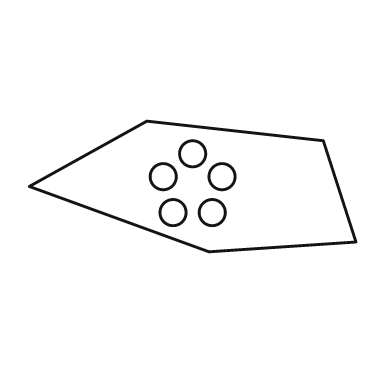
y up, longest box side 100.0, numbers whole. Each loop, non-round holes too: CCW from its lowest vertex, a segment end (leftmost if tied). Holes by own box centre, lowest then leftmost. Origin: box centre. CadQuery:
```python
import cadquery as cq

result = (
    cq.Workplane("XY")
    .moveTo(5.0, -20.0)
    .lineTo(50.0, -17.0)
    .lineTo(40.0, 14.0)
    .lineTo(-14.0, 20.0)
    .lineTo(-50.0, 0.0)
    .close()
    .moveTo(-6.0, -8.0)
    .circle(4.0)
    .moveTo(6.0, -8.0)
    .circle(4.0)
    .moveTo(-9.0, 3.0)
    .circle(4.0)
    .moveTo(9.0, 3.0)
    .circle(4.0)
    .moveTo(0.0, 10.0)
    .circle(4.0)
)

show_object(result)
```